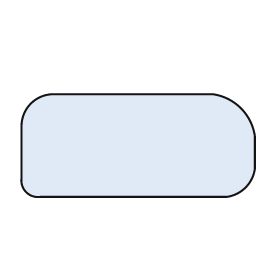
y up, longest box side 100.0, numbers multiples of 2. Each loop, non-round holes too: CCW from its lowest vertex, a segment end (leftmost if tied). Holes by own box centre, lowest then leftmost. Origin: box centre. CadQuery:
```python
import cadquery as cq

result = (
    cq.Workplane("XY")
    .moveTo(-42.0, -22.0)
    .lineTo(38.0, -22.0)
    .threePointArc((46.0, -18.0), (50.0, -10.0))
    .lineTo(50.0, 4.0)
    .threePointArc((44.0, 16.0), (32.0, 22.0))
    .lineTo(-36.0, 22.0)
    .threePointArc((-46.0, 18.0), (-50.0, 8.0))
    .lineTo(-50.0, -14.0)
    .threePointArc((-48.0, -20.0), (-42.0, -22.0))
    .close()
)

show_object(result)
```